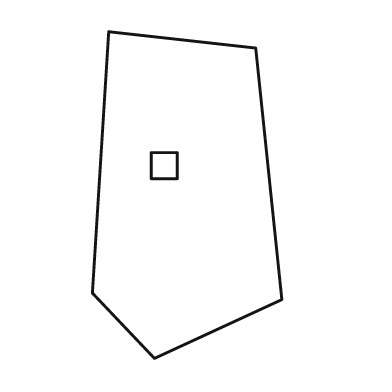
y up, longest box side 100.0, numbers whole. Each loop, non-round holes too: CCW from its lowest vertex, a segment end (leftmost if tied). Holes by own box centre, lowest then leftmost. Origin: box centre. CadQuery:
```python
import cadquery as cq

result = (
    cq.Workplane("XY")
    .moveTo(-10.0, -50.0)
    .lineTo(29.0, -32.0)
    .lineTo(21.0, 45.0)
    .lineTo(-24.0, 50.0)
    .lineTo(-29.0, -30.0)
    .close()
    .moveTo(-11.0, 5.0)
    .lineTo(-3.0, 5.0)
    .lineTo(-3.0, 13.0)
    .lineTo(-11.0, 13.0)
    .close()
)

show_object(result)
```